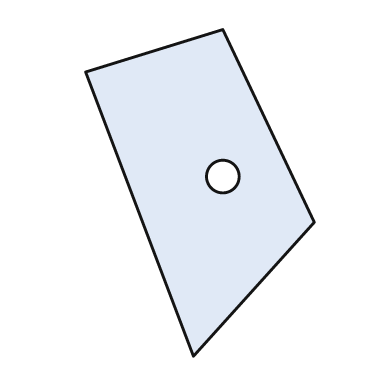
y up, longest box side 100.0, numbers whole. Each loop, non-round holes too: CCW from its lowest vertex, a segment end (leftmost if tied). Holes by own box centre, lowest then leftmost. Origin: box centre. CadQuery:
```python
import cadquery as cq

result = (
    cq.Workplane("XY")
    .moveTo(-2.0, -50.0)
    .lineTo(35.0, -9.0)
    .lineTo(7.0, 50.0)
    .lineTo(-35.0, 37.0)
    .close()
    .moveTo(7.0, 5.0)
    .circle(5.0)
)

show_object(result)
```